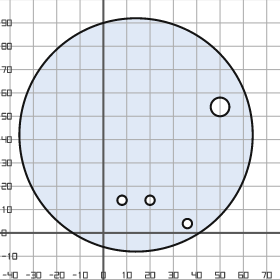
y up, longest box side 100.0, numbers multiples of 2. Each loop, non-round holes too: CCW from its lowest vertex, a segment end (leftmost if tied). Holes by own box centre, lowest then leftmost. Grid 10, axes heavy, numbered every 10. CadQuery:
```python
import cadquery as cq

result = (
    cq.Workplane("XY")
    .moveTo(14.0, 42.0)
    .circle(50.0)
    .moveTo(36.0, 4.0)
    .circle(2.0)
    .moveTo(8.0, 14.0)
    .circle(2.0)
    .moveTo(20.0, 14.0)
    .circle(2.0)
    .moveTo(50.0, 54.0)
    .circle(4.0)
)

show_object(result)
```